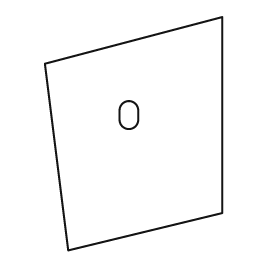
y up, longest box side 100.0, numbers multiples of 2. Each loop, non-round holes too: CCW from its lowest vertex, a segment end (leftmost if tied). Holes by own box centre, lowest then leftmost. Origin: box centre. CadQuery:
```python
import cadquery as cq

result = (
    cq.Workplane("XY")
    .moveTo(-28.0, -50.0)
    .lineTo(38.0, -34.0)
    .lineTo(38.0, 50.0)
    .lineTo(-38.0, 30.0)
    .close()
    .moveTo(-6.0, 6.0)
    .threePointArc((-2.0, 2.0), (2.0, 6.0))
    .lineTo(2.0, 10.0)
    .threePointArc((-2.0, 14.0), (-6.0, 10.0))
    .close()
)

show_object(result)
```